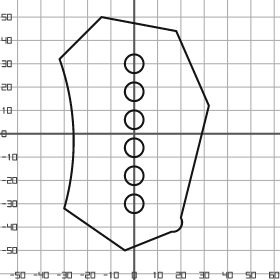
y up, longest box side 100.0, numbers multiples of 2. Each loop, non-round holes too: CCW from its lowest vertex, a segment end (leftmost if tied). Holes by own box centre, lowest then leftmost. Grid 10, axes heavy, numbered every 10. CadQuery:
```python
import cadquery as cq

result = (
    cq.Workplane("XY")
    .moveTo(-4.0, -50.0)
    .lineTo(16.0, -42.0)
    .threePointArc((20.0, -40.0), (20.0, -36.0))
    .lineTo(32.0, 12.0)
    .lineTo(18.0, 44.0)
    .lineTo(-14.0, 50.0)
    .lineTo(-32.0, 32.0)
    .threePointArc((-26.0, 0.0), (-30.0, -32.0))
    .close()
    .moveTo(0.0, -30.0)
    .circle(4.0)
    .moveTo(0.0, -18.0)
    .circle(4.0)
    .moveTo(0.0, -6.0)
    .circle(4.0)
    .moveTo(0.0, 6.0)
    .circle(4.0)
    .moveTo(0.0, 18.0)
    .circle(4.0)
    .moveTo(0.0, 30.0)
    .circle(4.0)
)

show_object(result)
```